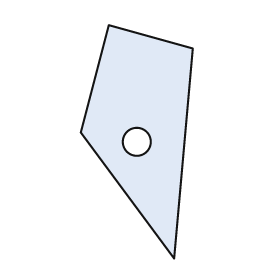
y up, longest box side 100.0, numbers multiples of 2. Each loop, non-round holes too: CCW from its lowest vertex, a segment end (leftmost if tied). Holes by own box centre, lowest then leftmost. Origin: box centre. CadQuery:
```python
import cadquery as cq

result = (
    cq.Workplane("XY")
    .moveTo(16.0, -50.0)
    .lineTo(24.0, 40.0)
    .lineTo(-12.0, 50.0)
    .lineTo(-24.0, 4.0)
    .close()
    .moveTo(0.0, 0.0)
    .circle(6.0)
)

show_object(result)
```